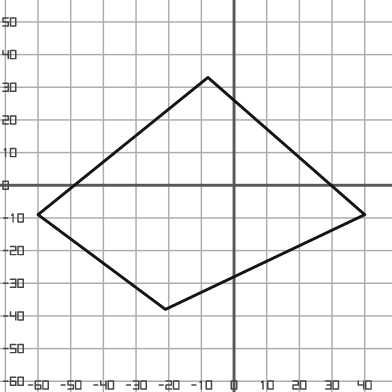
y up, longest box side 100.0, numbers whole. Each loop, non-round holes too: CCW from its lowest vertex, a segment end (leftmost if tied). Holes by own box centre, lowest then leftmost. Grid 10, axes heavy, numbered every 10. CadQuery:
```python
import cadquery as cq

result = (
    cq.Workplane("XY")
    .moveTo(-21.0, -38.0)
    .lineTo(40.0, -9.0)
    .lineTo(-8.0, 33.0)
    .lineTo(-60.0, -9.0)
    .close()
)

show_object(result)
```